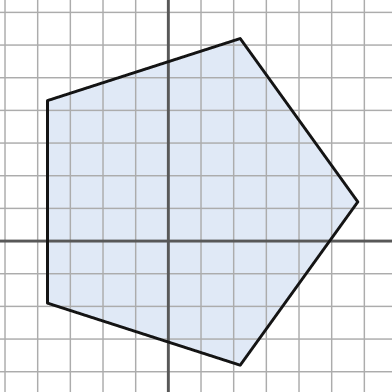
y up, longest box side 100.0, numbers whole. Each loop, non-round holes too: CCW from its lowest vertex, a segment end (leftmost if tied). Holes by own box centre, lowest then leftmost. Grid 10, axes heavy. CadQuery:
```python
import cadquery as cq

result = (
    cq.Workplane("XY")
    .moveTo(22.0, -38.0)
    .lineTo(58.0, 12.0)
    .lineTo(22.0, 62.0)
    .lineTo(-37.0, 43.0)
    .lineTo(-37.0, -19.0)
    .close()
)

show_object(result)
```